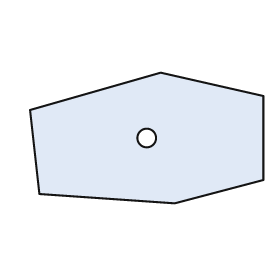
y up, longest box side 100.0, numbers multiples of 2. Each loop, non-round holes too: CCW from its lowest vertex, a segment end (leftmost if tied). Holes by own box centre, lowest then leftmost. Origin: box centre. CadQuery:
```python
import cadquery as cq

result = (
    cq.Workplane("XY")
    .moveTo(12.0, -28.0)
    .lineTo(50.0, -18.0)
    .lineTo(50.0, 18.0)
    .lineTo(6.0, 28.0)
    .lineTo(-50.0, 12.0)
    .lineTo(-46.0, -24.0)
    .close()
    .moveTo(0.0, 0.0)
    .circle(4.0)
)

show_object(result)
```